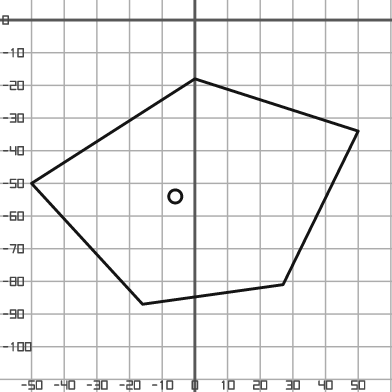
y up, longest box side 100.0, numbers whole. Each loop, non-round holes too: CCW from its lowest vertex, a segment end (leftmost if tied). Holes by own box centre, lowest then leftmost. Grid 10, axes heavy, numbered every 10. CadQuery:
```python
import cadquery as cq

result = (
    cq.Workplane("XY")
    .moveTo(-16.0, -87.0)
    .lineTo(27.0, -81.0)
    .lineTo(50.0, -34.0)
    .lineTo(0.0, -18.0)
    .lineTo(-50.0, -50.0)
    .close()
    .moveTo(-6.0, -54.0)
    .circle(2.0)
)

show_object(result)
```